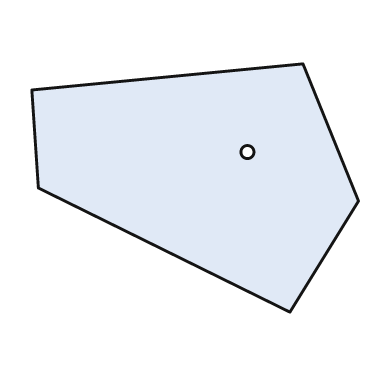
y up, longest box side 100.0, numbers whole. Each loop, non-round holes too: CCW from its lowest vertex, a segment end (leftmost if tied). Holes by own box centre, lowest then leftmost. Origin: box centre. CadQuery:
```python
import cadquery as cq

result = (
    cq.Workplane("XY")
    .moveTo(29.0, -38.0)
    .lineTo(50.0, -4.0)
    .lineTo(33.0, 38.0)
    .lineTo(-50.0, 30.0)
    .lineTo(-48.0, 0.0)
    .close()
    .moveTo(16.0, 11.0)
    .circle(2.0)
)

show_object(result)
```